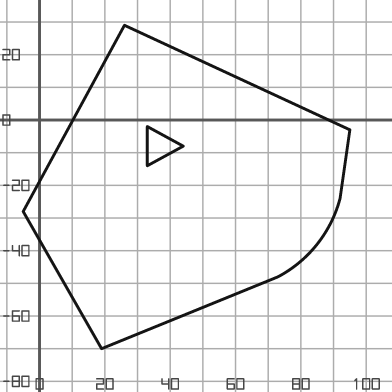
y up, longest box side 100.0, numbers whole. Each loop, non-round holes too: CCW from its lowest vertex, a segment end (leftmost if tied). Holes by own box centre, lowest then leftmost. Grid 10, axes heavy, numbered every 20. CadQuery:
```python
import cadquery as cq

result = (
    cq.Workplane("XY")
    .moveTo(19.0, -70.0)
    .lineTo(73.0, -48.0)
    .threePointArc((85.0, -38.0), (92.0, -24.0))
    .lineTo(95.0, -3.0)
    .lineTo(26.0, 29.0)
    .lineTo(-5.0, -28.0)
    .close()
    .moveTo(33.0, -14.0)
    .lineTo(44.0, -8.0)
    .lineTo(33.0, -2.0)
    .close()
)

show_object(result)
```